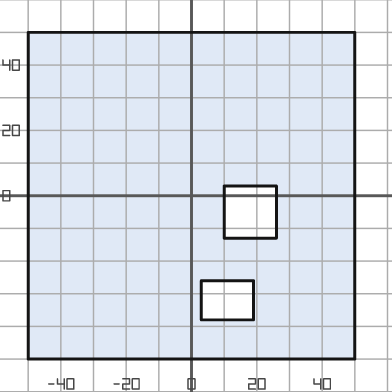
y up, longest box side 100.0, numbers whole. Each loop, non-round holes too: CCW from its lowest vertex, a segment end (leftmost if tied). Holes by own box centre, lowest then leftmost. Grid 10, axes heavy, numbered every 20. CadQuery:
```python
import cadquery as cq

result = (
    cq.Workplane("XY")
    .moveTo(-50.0, -50.0)
    .lineTo(50.0, -50.0)
    .lineTo(50.0, 50.0)
    .lineTo(-50.0, 50.0)
    .close()
    .moveTo(3.0, -38.0)
    .lineTo(19.0, -38.0)
    .lineTo(19.0, -26.0)
    .lineTo(3.0, -26.0)
    .close()
    .moveTo(10.0, -13.0)
    .lineTo(26.0, -13.0)
    .lineTo(26.0, 3.0)
    .lineTo(10.0, 3.0)
    .close()
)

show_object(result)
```